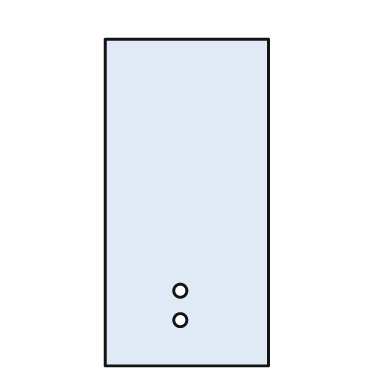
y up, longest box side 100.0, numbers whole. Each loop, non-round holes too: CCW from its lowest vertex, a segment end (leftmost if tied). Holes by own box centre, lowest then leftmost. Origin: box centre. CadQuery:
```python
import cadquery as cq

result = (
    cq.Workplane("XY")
    .moveTo(-25.0, -50.0)
    .lineTo(25.0, -50.0)
    .lineTo(25.0, 50.0)
    .lineTo(-25.0, 50.0)
    .close()
    .moveTo(-2.0, -36.0)
    .circle(2.0)
    .moveTo(-2.0, -27.0)
    .circle(2.0)
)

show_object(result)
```